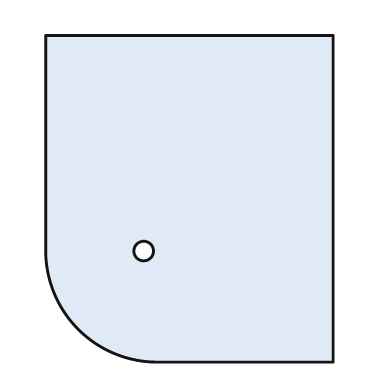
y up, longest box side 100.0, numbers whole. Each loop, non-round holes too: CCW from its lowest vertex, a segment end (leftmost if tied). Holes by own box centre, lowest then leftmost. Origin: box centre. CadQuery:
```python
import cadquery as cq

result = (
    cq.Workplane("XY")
    .moveTo(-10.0, -50.0)
    .lineTo(44.0, -50.0)
    .lineTo(44.0, 50.0)
    .lineTo(-44.0, 50.0)
    .lineTo(-44.0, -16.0)
    .threePointArc((-34.0, -40.0), (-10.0, -50.0))
    .close()
    .moveTo(-14.0, -16.0)
    .circle(3.0)
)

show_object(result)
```